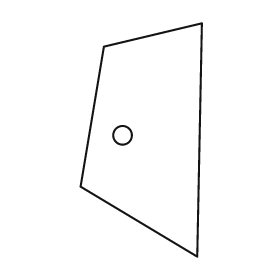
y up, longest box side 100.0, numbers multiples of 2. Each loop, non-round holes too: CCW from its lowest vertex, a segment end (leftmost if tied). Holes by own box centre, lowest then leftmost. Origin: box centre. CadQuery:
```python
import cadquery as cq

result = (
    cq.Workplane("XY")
    .moveTo(24.0, -50.0)
    .lineTo(26.0, 50.0)
    .lineTo(-16.0, 40.0)
    .lineTo(-26.0, -20.0)
    .close()
    .moveTo(-8.0, 2.0)
    .circle(4.0)
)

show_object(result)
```